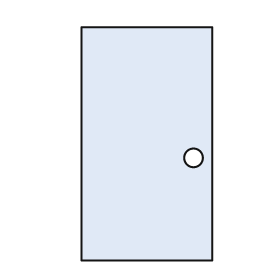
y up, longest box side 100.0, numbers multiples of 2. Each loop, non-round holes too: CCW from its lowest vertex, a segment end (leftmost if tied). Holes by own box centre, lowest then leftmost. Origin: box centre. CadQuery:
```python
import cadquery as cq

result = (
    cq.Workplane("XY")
    .moveTo(-28.0, -50.0)
    .lineTo(28.0, -50.0)
    .lineTo(28.0, 50.0)
    .lineTo(-28.0, 50.0)
    .close()
    .moveTo(20.0, -6.0)
    .circle(4.0)
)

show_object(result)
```